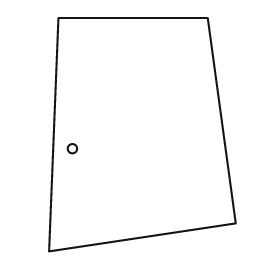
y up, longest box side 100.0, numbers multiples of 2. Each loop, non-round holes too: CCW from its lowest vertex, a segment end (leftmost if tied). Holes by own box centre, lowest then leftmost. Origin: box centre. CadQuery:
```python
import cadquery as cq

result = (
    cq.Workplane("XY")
    .moveTo(-40.0, -50.0)
    .lineTo(40.0, -38.0)
    .lineTo(28.0, 50.0)
    .lineTo(-36.0, 50.0)
    .close()
    .moveTo(-30.0, -6.0)
    .circle(2.0)
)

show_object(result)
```